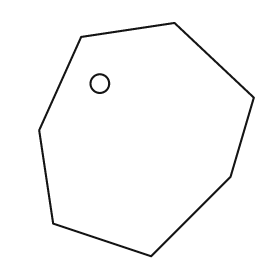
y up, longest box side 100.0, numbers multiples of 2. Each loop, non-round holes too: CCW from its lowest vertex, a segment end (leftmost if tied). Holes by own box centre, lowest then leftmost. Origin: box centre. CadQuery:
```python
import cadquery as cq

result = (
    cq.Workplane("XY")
    .moveTo(2.0, -50.0)
    .lineTo(36.0, -16.0)
    .lineTo(46.0, 18.0)
    .lineTo(12.0, 50.0)
    .lineTo(-28.0, 44.0)
    .lineTo(-46.0, 4.0)
    .lineTo(-40.0, -36.0)
    .close()
    .moveTo(-20.0, 24.0)
    .circle(4.0)
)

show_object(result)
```